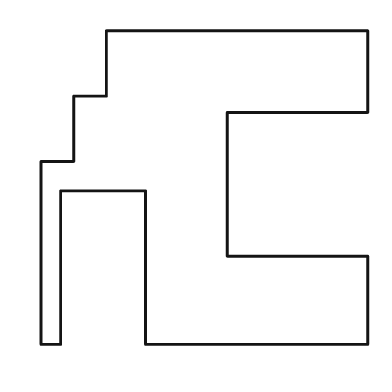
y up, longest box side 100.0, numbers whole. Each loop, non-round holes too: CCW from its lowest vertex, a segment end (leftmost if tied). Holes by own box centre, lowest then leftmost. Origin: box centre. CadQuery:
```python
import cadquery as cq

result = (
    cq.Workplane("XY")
    .moveTo(-50.0, -48.0)
    .lineTo(-44.0, -48.0)
    .lineTo(-44.0, -1.0)
    .lineTo(-18.0, -1.0)
    .lineTo(-18.0, -48.0)
    .lineTo(50.0, -48.0)
    .lineTo(50.0, -21.0)
    .lineTo(7.0, -21.0)
    .lineTo(7.0, 23.0)
    .lineTo(50.0, 23.0)
    .lineTo(50.0, 48.0)
    .lineTo(-30.0, 48.0)
    .lineTo(-30.0, 28.0)
    .lineTo(-40.0, 28.0)
    .lineTo(-40.0, 8.0)
    .lineTo(-50.0, 8.0)
    .close()
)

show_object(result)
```